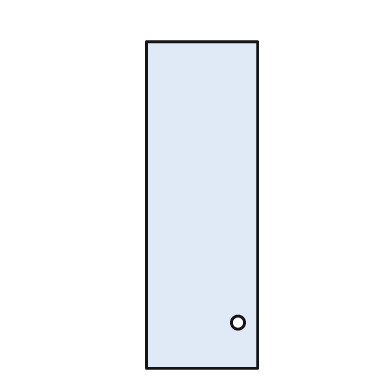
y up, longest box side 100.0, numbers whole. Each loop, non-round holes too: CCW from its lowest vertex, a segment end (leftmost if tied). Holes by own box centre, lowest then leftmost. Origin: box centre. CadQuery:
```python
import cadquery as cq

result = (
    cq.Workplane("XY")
    .moveTo(-17.0, -50.0)
    .lineTo(17.0, -50.0)
    .lineTo(17.0, 50.0)
    .lineTo(-17.0, 50.0)
    .close()
    .moveTo(11.0, -36.0)
    .circle(2.0)
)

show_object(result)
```